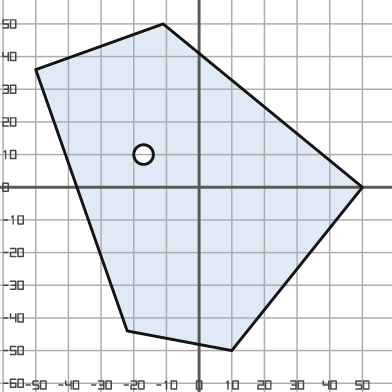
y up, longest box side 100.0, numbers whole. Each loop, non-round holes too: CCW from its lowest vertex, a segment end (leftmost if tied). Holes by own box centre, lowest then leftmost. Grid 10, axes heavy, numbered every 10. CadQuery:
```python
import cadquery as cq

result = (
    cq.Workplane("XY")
    .moveTo(10.0, -50.0)
    .lineTo(50.0, 0.0)
    .lineTo(-11.0, 50.0)
    .lineTo(-50.0, 36.0)
    .lineTo(-22.0, -44.0)
    .close()
    .moveTo(-17.0, 10.0)
    .circle(3.0)
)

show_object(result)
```